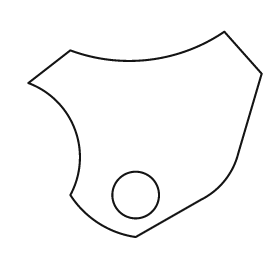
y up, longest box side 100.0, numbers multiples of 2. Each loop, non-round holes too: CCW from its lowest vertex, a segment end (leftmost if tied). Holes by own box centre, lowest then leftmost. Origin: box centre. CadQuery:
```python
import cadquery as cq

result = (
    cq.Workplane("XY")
    .moveTo(-4.0, -44.0)
    .lineTo(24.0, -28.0)
    .threePointArc((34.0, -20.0), (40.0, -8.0))
    .lineTo(50.0, 26.0)
    .lineTo(34.0, 44.0)
    .threePointArc((2.0, 32.0), (-32.0, 36.0))
    .lineTo(-50.0, 22.0)
    .threePointArc((-30.0, 2.0), (-32.0, -26.0))
    .threePointArc((-20.0, -38.0), (-4.0, -44.0))
    .close()
    .moveTo(-4.0, -26.0)
    .circle(10.0)
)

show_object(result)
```